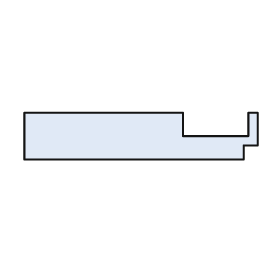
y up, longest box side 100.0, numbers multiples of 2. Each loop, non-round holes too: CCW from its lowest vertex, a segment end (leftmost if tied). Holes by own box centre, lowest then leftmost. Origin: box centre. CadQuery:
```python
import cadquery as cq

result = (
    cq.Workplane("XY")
    .moveTo(-50.0, -10.0)
    .lineTo(44.0, -10.0)
    .lineTo(44.0, -4.0)
    .lineTo(50.0, -4.0)
    .lineTo(50.0, 10.0)
    .lineTo(46.0, 10.0)
    .lineTo(46.0, 0.0)
    .lineTo(18.0, 0.0)
    .lineTo(18.0, 10.0)
    .lineTo(-50.0, 10.0)
    .close()
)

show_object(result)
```